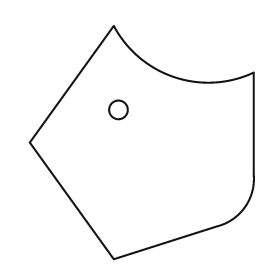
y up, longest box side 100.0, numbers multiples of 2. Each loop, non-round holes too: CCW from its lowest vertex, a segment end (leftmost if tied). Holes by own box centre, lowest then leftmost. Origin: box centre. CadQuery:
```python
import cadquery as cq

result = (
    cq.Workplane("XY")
    .moveTo(-12.0, -50.0)
    .lineTo(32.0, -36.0)
    .threePointArc((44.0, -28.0), (48.0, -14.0))
    .lineTo(48.0, 30.0)
    .threePointArc((14.0, 28.0), (-12.0, 50.0))
    .lineTo(-48.0, 0.0)
    .close()
    .moveTo(-10.0, 14.0)
    .circle(4.0)
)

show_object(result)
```